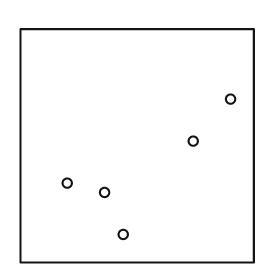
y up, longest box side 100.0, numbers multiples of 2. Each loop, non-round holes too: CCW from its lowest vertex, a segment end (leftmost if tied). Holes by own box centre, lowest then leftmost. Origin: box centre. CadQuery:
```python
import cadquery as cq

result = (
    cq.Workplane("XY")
    .moveTo(-50.0, -50.0)
    .lineTo(50.0, -50.0)
    .lineTo(50.0, 50.0)
    .lineTo(-50.0, 50.0)
    .close()
    .moveTo(-6.0, -38.0)
    .circle(2.0)
    .moveTo(-14.0, -20.0)
    .circle(2.0)
    .moveTo(-30.0, -16.0)
    .circle(2.0)
    .moveTo(24.0, 2.0)
    .circle(2.0)
    .moveTo(40.0, 20.0)
    .circle(2.0)
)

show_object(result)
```